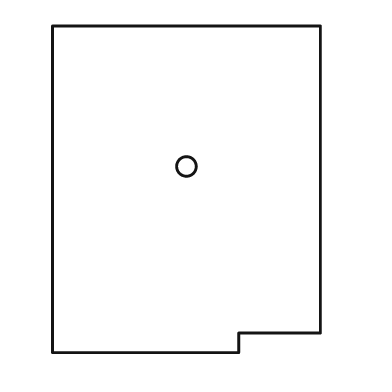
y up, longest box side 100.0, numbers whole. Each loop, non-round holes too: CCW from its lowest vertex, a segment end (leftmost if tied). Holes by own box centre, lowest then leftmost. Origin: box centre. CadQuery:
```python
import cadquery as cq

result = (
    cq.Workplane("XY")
    .moveTo(-41.0, -50.0)
    .lineTo(16.0, -50.0)
    .lineTo(16.0, -44.0)
    .lineTo(41.0, -44.0)
    .lineTo(41.0, 50.0)
    .lineTo(-41.0, 50.0)
    .close()
    .moveTo(0.0, 7.0)
    .circle(3.0)
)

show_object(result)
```